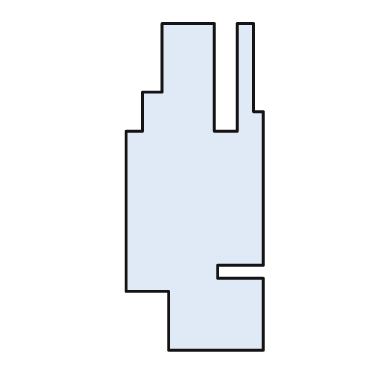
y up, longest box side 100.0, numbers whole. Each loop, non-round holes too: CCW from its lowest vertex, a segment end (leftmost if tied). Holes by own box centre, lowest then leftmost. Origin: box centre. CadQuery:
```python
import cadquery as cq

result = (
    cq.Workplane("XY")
    .moveTo(-8.0, -50.0)
    .lineTo(21.0, -50.0)
    .lineTo(21.0, -28.0)
    .lineTo(7.0, -28.0)
    .lineTo(7.0, -24.0)
    .lineTo(21.0, -24.0)
    .lineTo(21.0, 23.0)
    .lineTo(18.0, 23.0)
    .lineTo(18.0, 50.0)
    .lineTo(13.0, 50.0)
    .lineTo(13.0, 17.0)
    .lineTo(6.0, 17.0)
    .lineTo(6.0, 50.0)
    .lineTo(-10.0, 50.0)
    .lineTo(-10.0, 29.0)
    .lineTo(-16.0, 29.0)
    .lineTo(-16.0, 17.0)
    .lineTo(-21.0, 17.0)
    .lineTo(-21.0, -32.0)
    .lineTo(-8.0, -32.0)
    .close()
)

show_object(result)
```